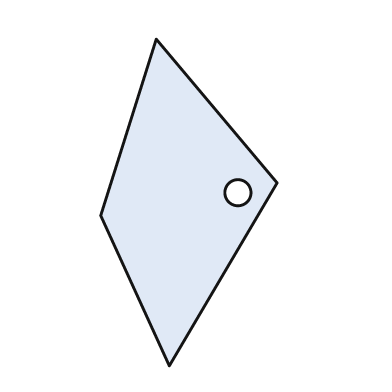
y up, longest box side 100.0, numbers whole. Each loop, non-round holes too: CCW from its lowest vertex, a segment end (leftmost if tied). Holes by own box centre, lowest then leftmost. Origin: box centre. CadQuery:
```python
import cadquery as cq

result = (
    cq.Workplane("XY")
    .moveTo(-6.0, -50.0)
    .lineTo(27.0, 6.0)
    .lineTo(-10.0, 50.0)
    .lineTo(-27.0, -4.0)
    .close()
    .moveTo(15.0, 3.0)
    .circle(4.0)
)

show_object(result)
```